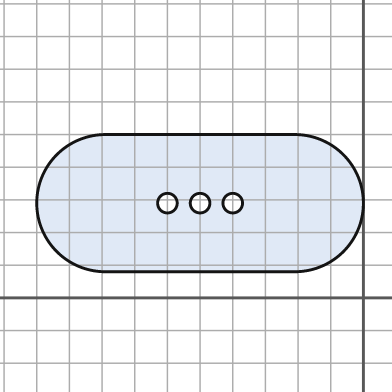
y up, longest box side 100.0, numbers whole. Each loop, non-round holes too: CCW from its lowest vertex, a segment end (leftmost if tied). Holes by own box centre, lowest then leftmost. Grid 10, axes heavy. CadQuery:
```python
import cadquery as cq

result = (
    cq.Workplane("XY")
    .moveTo(-79.0, 8.0)
    .lineTo(-21.0, 8.0)
    .threePointArc((0.0, 29.0), (-21.0, 50.0))
    .lineTo(-79.0, 50.0)
    .threePointArc((-100.0, 29.0), (-79.0, 8.0))
    .close()
    .moveTo(-60.0, 29.0)
    .circle(3.0)
    .moveTo(-50.0, 29.0)
    .circle(3.0)
    .moveTo(-40.0, 29.0)
    .circle(3.0)
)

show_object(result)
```